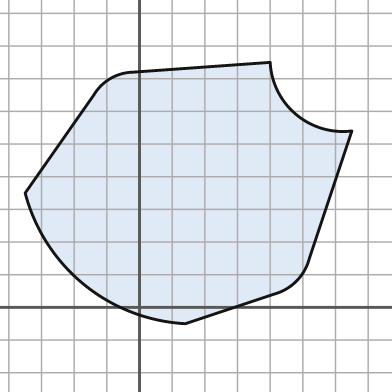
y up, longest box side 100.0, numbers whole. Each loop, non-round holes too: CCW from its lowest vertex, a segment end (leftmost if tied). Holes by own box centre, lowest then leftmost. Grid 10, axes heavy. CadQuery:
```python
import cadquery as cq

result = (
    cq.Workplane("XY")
    .moveTo(14.0, -5.0)
    .lineTo(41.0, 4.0)
    .threePointArc((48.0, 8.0), (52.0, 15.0))
    .lineTo(65.0, 54.0)
    .threePointArc((48.0, 59.0), (40.0, 75.0))
    .lineTo(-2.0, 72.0)
    .threePointArc((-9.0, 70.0), (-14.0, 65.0))
    .lineTo(-35.0, 35.0)
    .threePointArc((-17.0, 7.0), (14.0, -5.0))
    .close()
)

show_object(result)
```